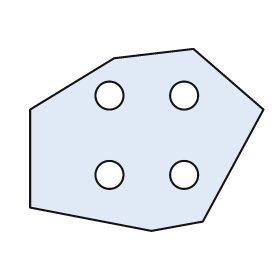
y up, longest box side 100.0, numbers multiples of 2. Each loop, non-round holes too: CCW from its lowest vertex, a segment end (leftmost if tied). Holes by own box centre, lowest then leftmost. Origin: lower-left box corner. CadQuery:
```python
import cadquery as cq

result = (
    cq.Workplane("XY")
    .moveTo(52.0, 0.0)
    .lineTo(74.0, 4.0)
    .lineTo(100.0, 52.0)
    .lineTo(70.0, 78.0)
    .lineTo(36.0, 74.0)
    .lineTo(0.0, 52.0)
    .lineTo(0.0, 10.0)
    .close()
    .moveTo(34.0, 24.0)
    .circle(6.0)
    .moveTo(66.0, 24.0)
    .circle(6.0)
    .moveTo(34.0, 58.0)
    .circle(6.0)
    .moveTo(66.0, 58.0)
    .circle(6.0)
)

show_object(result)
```